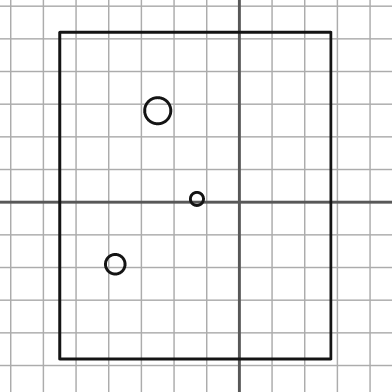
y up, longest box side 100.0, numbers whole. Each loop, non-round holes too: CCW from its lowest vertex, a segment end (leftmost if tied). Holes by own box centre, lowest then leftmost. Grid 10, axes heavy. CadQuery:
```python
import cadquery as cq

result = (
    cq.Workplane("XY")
    .moveTo(-55.0, -48.0)
    .lineTo(28.0, -48.0)
    .lineTo(28.0, 52.0)
    .lineTo(-55.0, 52.0)
    .close()
    .moveTo(-38.0, -19.0)
    .circle(3.0)
    .moveTo(-13.0, 1.0)
    .circle(2.0)
    .moveTo(-25.0, 28.0)
    .circle(4.0)
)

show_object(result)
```